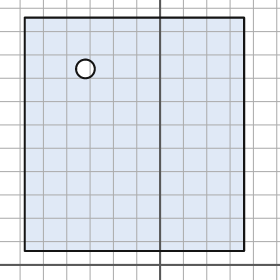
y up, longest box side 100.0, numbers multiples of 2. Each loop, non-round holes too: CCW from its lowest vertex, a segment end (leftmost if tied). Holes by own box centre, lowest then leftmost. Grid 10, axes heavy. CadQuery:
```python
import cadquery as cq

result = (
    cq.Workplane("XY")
    .moveTo(-58.0, 6.0)
    .lineTo(36.0, 6.0)
    .lineTo(36.0, 106.0)
    .lineTo(-58.0, 106.0)
    .close()
    .moveTo(-32.0, 84.0)
    .circle(4.0)
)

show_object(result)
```